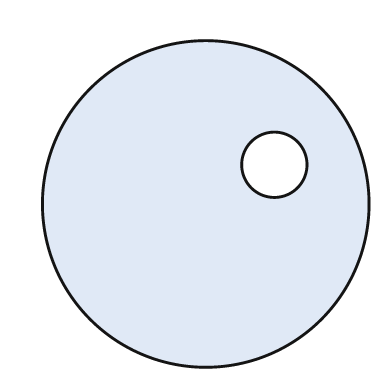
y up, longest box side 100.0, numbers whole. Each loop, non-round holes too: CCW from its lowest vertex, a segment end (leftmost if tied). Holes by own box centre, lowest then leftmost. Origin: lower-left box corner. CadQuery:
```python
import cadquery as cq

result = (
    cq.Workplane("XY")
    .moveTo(50.0, 50.0)
    .circle(50.0)
    .moveTo(71.0, 62.0)
    .circle(10.0)
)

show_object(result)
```